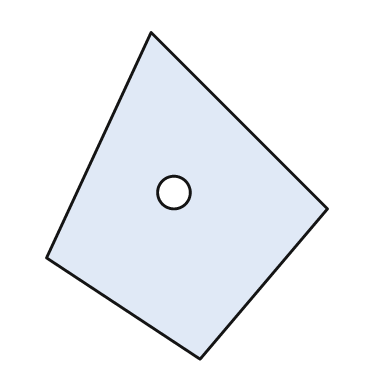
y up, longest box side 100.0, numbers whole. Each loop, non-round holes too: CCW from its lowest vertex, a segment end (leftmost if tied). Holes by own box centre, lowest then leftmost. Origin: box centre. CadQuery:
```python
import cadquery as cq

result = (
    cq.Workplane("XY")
    .moveTo(4.0, -50.0)
    .lineTo(43.0, -4.0)
    .lineTo(-11.0, 50.0)
    .lineTo(-43.0, -19.0)
    .close()
    .moveTo(-4.0, 1.0)
    .circle(5.0)
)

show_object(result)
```